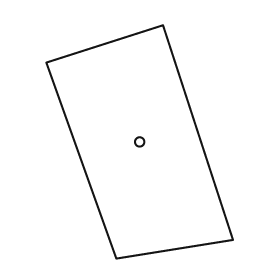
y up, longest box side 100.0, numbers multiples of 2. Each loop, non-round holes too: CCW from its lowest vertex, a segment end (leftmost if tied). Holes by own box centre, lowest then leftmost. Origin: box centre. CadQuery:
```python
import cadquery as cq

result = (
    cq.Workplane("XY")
    .moveTo(-10.0, -50.0)
    .lineTo(40.0, -42.0)
    .lineTo(10.0, 50.0)
    .lineTo(-40.0, 34.0)
    .close()
    .moveTo(0.0, 0.0)
    .circle(2.0)
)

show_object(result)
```